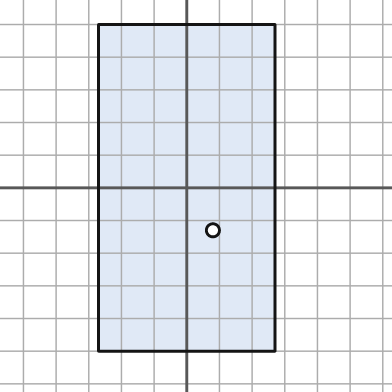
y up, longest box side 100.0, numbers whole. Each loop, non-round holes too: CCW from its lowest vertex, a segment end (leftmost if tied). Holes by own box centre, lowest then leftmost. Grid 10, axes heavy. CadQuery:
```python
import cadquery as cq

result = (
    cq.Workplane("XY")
    .moveTo(-27.0, -50.0)
    .lineTo(27.0, -50.0)
    .lineTo(27.0, 50.0)
    .lineTo(-27.0, 50.0)
    .close()
    .moveTo(8.0, -13.0)
    .circle(2.0)
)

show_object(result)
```